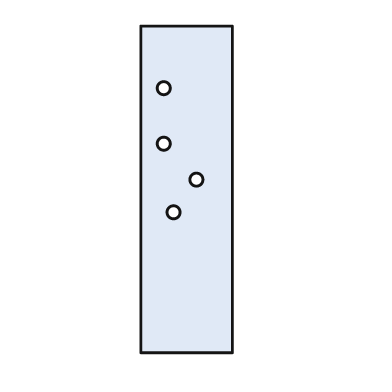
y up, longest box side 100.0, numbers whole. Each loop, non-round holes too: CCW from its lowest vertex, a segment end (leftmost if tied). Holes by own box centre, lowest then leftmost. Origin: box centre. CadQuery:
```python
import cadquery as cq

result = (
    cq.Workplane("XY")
    .moveTo(-14.0, -50.0)
    .lineTo(14.0, -50.0)
    .lineTo(14.0, 50.0)
    .lineTo(-14.0, 50.0)
    .close()
    .moveTo(-4.0, -7.0)
    .circle(2.0)
    .moveTo(3.0, 3.0)
    .circle(2.0)
    .moveTo(-7.0, 14.0)
    .circle(2.0)
    .moveTo(-7.0, 31.0)
    .circle(2.0)
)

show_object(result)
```